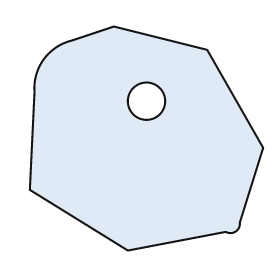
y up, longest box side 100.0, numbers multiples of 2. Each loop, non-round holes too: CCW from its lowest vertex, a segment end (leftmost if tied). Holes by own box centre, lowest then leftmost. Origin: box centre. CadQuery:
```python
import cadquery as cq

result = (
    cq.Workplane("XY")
    .moveTo(-8.0, -48.0)
    .lineTo(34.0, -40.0)
    .threePointArc((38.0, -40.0), (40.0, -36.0))
    .lineTo(50.0, -4.0)
    .lineTo(26.0, 38.0)
    .lineTo(-14.0, 48.0)
    .lineTo(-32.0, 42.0)
    .threePointArc((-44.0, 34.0), (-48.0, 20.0))
    .lineTo(-50.0, -22.0)
    .close()
    .moveTo(0.0, 16.0)
    .circle(8.0)
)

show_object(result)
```